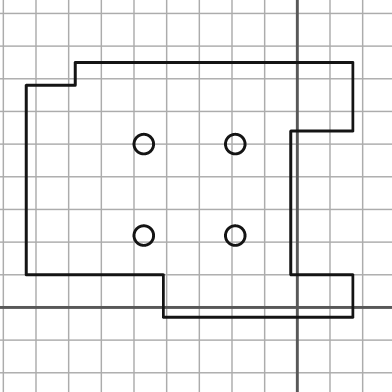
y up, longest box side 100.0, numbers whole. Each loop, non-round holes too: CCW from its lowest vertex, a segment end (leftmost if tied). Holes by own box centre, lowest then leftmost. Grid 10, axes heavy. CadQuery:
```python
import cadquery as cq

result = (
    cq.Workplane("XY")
    .moveTo(-41.0, -3.0)
    .lineTo(17.0, -3.0)
    .lineTo(17.0, 10.0)
    .lineTo(-2.0, 10.0)
    .lineTo(-2.0, 54.0)
    .lineTo(17.0, 54.0)
    .lineTo(17.0, 75.0)
    .lineTo(-68.0, 75.0)
    .lineTo(-68.0, 68.0)
    .lineTo(-83.0, 68.0)
    .lineTo(-83.0, 10.0)
    .lineTo(-41.0, 10.0)
    .close()
    .moveTo(-47.0, 22.0)
    .circle(3.0)
    .moveTo(-19.0, 22.0)
    .circle(3.0)
    .moveTo(-47.0, 50.0)
    .circle(3.0)
    .moveTo(-19.0, 50.0)
    .circle(3.0)
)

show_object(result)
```